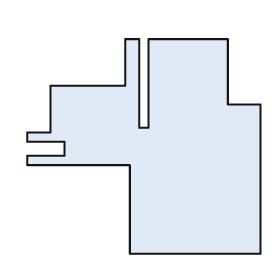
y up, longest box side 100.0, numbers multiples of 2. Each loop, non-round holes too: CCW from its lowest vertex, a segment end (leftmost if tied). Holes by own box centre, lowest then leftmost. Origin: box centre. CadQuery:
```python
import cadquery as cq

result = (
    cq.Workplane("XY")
    .moveTo(-6.0, -46.0)
    .lineTo(50.0, -46.0)
    .lineTo(50.0, 18.0)
    .lineTo(36.0, 18.0)
    .lineTo(36.0, 46.0)
    .lineTo(2.0, 46.0)
    .lineTo(2.0, 8.0)
    .lineTo(-2.0, 8.0)
    .lineTo(-2.0, 46.0)
    .lineTo(-8.0, 46.0)
    .lineTo(-8.0, 26.0)
    .lineTo(-40.0, 26.0)
    .lineTo(-40.0, 6.0)
    .lineTo(-50.0, 6.0)
    .lineTo(-50.0, 2.0)
    .lineTo(-34.0, 2.0)
    .lineTo(-34.0, -4.0)
    .lineTo(-50.0, -4.0)
    .lineTo(-50.0, -8.0)
    .lineTo(-6.0, -8.0)
    .close()
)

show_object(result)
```